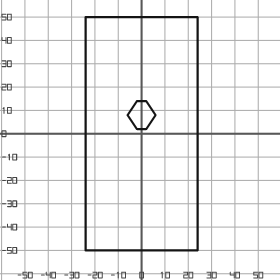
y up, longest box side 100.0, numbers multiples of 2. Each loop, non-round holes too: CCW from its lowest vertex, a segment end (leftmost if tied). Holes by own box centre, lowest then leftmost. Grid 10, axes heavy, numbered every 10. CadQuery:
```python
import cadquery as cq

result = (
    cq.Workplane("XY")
    .moveTo(-24.0, -50.0)
    .lineTo(24.0, -50.0)
    .lineTo(24.0, 50.0)
    .lineTo(-24.0, 50.0)
    .close()
    .moveTo(-2.0, 2.0)
    .lineTo(2.0, 2.0)
    .lineTo(6.0, 8.0)
    .lineTo(2.0, 14.0)
    .lineTo(-2.0, 14.0)
    .lineTo(-6.0, 8.0)
    .close()
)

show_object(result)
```